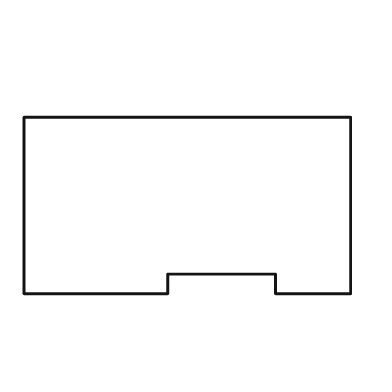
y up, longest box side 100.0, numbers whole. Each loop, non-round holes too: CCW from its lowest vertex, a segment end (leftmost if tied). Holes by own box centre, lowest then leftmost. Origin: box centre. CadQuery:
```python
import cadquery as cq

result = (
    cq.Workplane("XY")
    .moveTo(-50.0, -27.0)
    .lineTo(-6.0, -27.0)
    .lineTo(-6.0, -21.0)
    .lineTo(27.0, -21.0)
    .lineTo(27.0, -27.0)
    .lineTo(50.0, -27.0)
    .lineTo(50.0, 27.0)
    .lineTo(-50.0, 27.0)
    .close()
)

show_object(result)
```